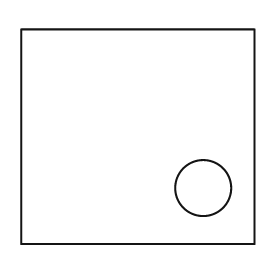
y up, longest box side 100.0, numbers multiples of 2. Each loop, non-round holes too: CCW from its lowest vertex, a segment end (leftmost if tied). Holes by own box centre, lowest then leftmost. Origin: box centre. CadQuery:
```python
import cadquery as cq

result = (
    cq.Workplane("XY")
    .moveTo(-50.0, -46.0)
    .lineTo(50.0, -46.0)
    .lineTo(50.0, 46.0)
    .lineTo(-50.0, 46.0)
    .close()
    .moveTo(28.0, -22.0)
    .circle(12.0)
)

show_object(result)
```